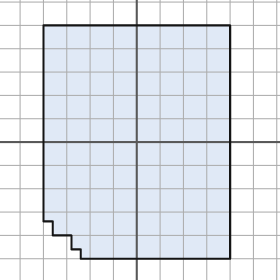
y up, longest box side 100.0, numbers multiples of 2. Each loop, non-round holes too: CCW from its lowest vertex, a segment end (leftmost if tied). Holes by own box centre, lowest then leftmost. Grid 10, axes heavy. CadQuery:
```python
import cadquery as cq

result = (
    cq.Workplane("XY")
    .moveTo(-24.0, -50.0)
    .lineTo(40.0, -50.0)
    .lineTo(40.0, 50.0)
    .lineTo(-40.0, 50.0)
    .lineTo(-40.0, -34.0)
    .lineTo(-36.0, -34.0)
    .lineTo(-36.0, -40.0)
    .lineTo(-28.0, -40.0)
    .lineTo(-28.0, -46.0)
    .lineTo(-24.0, -46.0)
    .close()
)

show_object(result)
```